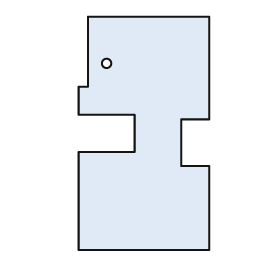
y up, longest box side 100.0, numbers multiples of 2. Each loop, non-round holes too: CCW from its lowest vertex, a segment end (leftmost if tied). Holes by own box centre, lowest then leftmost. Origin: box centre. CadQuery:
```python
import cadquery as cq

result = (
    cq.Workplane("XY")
    .moveTo(-28.0, -50.0)
    .lineTo(28.0, -50.0)
    .lineTo(28.0, -14.0)
    .lineTo(16.0, -14.0)
    .lineTo(16.0, 6.0)
    .lineTo(28.0, 6.0)
    .lineTo(28.0, 50.0)
    .lineTo(-24.0, 50.0)
    .lineTo(-24.0, 20.0)
    .lineTo(-28.0, 20.0)
    .lineTo(-28.0, 8.0)
    .lineTo(-4.0, 8.0)
    .lineTo(-4.0, -8.0)
    .lineTo(-28.0, -8.0)
    .close()
    .moveTo(-16.0, 30.0)
    .circle(2.0)
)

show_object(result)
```